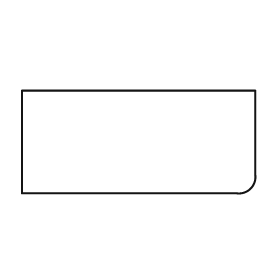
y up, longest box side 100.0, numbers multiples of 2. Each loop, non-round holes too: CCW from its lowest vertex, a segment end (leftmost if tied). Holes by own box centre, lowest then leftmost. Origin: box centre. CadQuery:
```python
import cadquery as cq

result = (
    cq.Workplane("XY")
    .moveTo(-50.0, -22.0)
    .lineTo(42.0, -22.0)
    .threePointArc((48.0, -20.0), (50.0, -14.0))
    .lineTo(50.0, 22.0)
    .lineTo(-50.0, 22.0)
    .close()
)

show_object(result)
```